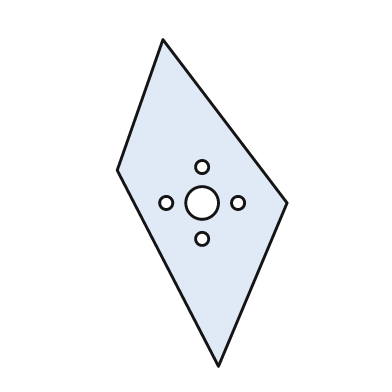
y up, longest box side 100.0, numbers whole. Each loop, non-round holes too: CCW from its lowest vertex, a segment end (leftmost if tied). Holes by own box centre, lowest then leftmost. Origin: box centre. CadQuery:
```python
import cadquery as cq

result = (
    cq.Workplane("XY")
    .moveTo(5.0, -50.0)
    .lineTo(26.0, 0.0)
    .lineTo(-12.0, 50.0)
    .lineTo(-26.0, 10.0)
    .close()
    .moveTo(0.0, -11.0)
    .circle(2.0)
    .moveTo(-11.0, 0.0)
    .circle(2.0)
    .moveTo(0.0, 0.0)
    .circle(5.0)
    .moveTo(11.0, 0.0)
    .circle(2.0)
    .moveTo(0.0, 11.0)
    .circle(2.0)
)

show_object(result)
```